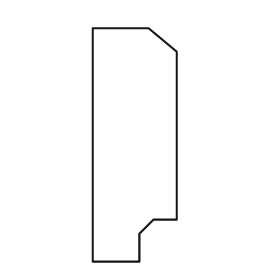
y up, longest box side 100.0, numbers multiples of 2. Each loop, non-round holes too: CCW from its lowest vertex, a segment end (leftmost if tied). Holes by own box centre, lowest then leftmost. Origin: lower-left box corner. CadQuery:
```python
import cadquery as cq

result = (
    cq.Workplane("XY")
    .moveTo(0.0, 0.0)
    .lineTo(20.0, 0.0)
    .lineTo(20.0, 12.0)
    .lineTo(26.0, 18.0)
    .lineTo(36.0, 18.0)
    .lineTo(36.0, 90.0)
    .lineTo(24.0, 100.0)
    .lineTo(0.0, 100.0)
    .close()
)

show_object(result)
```